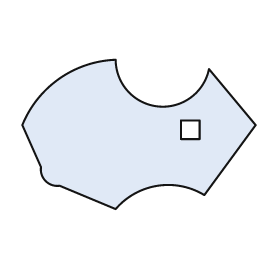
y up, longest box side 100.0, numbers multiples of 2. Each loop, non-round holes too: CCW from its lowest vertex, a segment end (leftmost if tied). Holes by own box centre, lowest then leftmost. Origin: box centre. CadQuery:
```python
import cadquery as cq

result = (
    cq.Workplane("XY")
    .moveTo(-10.0, -32.0)
    .threePointArc((8.0, -22.0), (28.0, -26.0))
    .lineTo(50.0, 4.0)
    .lineTo(30.0, 28.0)
    .threePointArc((8.0, 12.0), (-10.0, 32.0))
    .threePointArc((-34.0, 24.0), (-50.0, 4.0))
    .lineTo(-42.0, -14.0)
    .threePointArc((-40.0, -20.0), (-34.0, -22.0))
    .close()
    .moveTo(18.0, -2.0)
    .lineTo(26.0, -2.0)
    .lineTo(26.0, 6.0)
    .lineTo(18.0, 6.0)
    .close()
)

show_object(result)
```